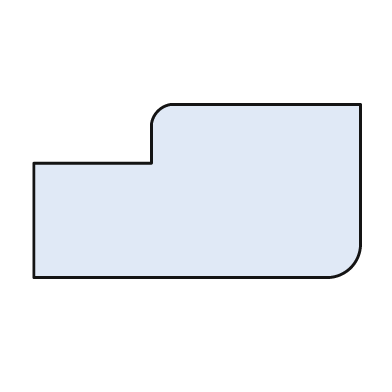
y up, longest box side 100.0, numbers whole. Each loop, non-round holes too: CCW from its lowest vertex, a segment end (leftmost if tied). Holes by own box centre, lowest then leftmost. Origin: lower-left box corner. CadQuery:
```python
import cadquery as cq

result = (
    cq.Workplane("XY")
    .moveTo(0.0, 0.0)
    .lineTo(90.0, 0.0)
    .threePointArc((97.0, 3.0), (100.0, 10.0))
    .lineTo(100.0, 53.0)
    .lineTo(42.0, 53.0)
    .threePointArc((38.0, 51.0), (36.0, 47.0))
    .lineTo(36.0, 35.0)
    .lineTo(0.0, 35.0)
    .close()
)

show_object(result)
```